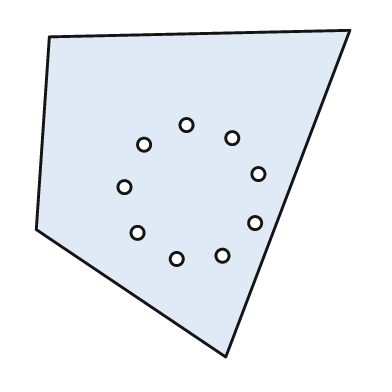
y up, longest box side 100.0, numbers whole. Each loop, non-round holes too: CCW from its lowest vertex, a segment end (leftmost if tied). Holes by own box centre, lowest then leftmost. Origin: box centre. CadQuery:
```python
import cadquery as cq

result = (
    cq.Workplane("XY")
    .moveTo(10.0, -50.0)
    .lineTo(48.0, 50.0)
    .lineTo(-44.0, 48.0)
    .lineTo(-48.0, -11.0)
    .close()
    .moveTo(-5.0, -20.0)
    .circle(2.0)
    .moveTo(9.0, -19.0)
    .circle(2.0)
    .moveTo(-17.0, -12.0)
    .circle(2.0)
    .moveTo(19.0, -9.0)
    .circle(2.0)
    .moveTo(-21.0, 2.0)
    .circle(2.0)
    .moveTo(20.0, 6.0)
    .circle(2.0)
    .moveTo(-15.0, 15.0)
    .circle(2.0)
    .moveTo(12.0, 17.0)
    .circle(2.0)
    .moveTo(-2.0, 21.0)
    .circle(2.0)
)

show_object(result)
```